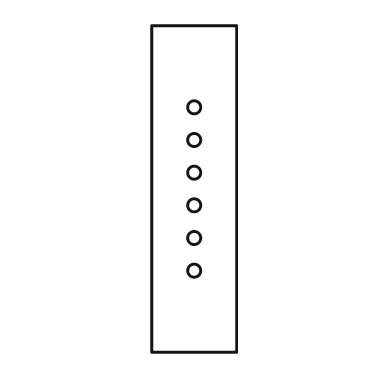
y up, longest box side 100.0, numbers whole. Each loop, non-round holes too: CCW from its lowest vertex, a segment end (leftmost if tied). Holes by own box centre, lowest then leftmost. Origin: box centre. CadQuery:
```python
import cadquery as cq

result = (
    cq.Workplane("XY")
    .moveTo(-13.0, -50.0)
    .lineTo(13.0, -50.0)
    .lineTo(13.0, 50.0)
    .lineTo(-13.0, 50.0)
    .close()
    .moveTo(0.0, -25.0)
    .circle(2.0)
    .moveTo(0.0, -15.0)
    .circle(2.0)
    .moveTo(0.0, -5.0)
    .circle(2.0)
    .moveTo(0.0, 5.0)
    .circle(2.0)
    .moveTo(0.0, 15.0)
    .circle(2.0)
    .moveTo(0.0, 25.0)
    .circle(2.0)
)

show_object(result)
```